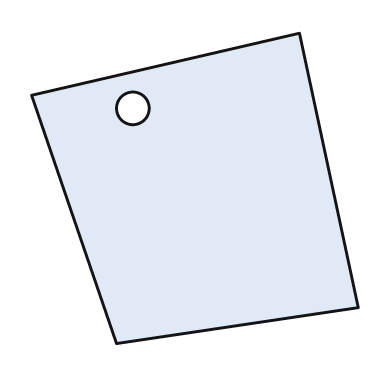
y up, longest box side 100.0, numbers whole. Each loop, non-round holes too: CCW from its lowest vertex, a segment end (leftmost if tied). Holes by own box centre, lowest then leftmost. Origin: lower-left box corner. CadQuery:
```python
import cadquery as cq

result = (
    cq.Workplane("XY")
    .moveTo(26.0, 0.0)
    .lineTo(100.0, 11.0)
    .lineTo(82.0, 95.0)
    .lineTo(0.0, 76.0)
    .close()
    .moveTo(31.0, 72.0)
    .circle(5.0)
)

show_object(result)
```